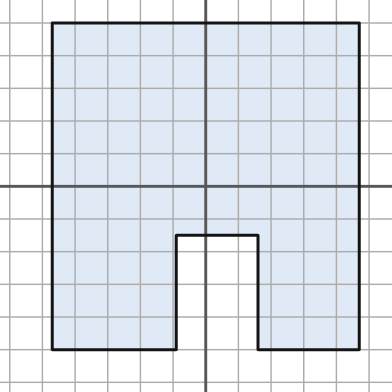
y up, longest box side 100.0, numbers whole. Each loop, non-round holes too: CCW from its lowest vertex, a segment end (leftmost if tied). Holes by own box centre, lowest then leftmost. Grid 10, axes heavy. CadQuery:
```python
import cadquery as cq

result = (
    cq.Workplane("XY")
    .moveTo(-47.0, -50.0)
    .lineTo(-9.0, -50.0)
    .lineTo(-9.0, -15.0)
    .lineTo(16.0, -15.0)
    .lineTo(16.0, -50.0)
    .lineTo(47.0, -50.0)
    .lineTo(47.0, 50.0)
    .lineTo(-47.0, 50.0)
    .close()
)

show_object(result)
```